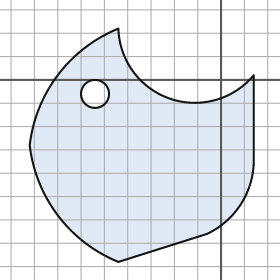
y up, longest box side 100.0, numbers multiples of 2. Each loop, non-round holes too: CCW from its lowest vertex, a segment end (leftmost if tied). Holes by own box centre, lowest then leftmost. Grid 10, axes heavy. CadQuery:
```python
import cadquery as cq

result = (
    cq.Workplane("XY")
    .moveTo(-44.0, -78.0)
    .lineTo(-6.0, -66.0)
    .threePointArc((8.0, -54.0), (14.0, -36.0))
    .lineTo(14.0, 2.0)
    .threePointArc((-22.0, -8.0), (-44.0, 22.0))
    .threePointArc((-70.0, 2.0), (-82.0, -28.0))
    .threePointArc((-70.0, -58.0), (-44.0, -78.0))
    .close()
    .moveTo(-54.0, -6.0)
    .circle(6.0)
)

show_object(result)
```